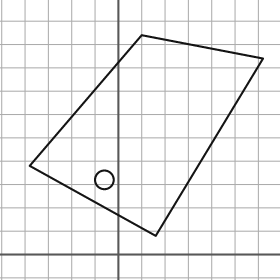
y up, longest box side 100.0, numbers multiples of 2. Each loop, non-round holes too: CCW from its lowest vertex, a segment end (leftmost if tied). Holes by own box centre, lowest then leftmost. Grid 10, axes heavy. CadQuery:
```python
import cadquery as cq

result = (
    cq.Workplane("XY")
    .moveTo(16.0, 8.0)
    .lineTo(62.0, 84.0)
    .lineTo(10.0, 94.0)
    .lineTo(-38.0, 38.0)
    .close()
    .moveTo(-6.0, 32.0)
    .circle(4.0)
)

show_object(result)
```